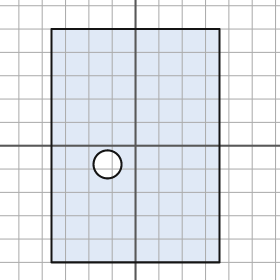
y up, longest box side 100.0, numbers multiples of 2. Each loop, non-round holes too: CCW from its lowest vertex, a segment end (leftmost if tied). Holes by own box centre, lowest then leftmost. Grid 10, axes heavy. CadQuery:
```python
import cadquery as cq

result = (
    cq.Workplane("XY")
    .moveTo(-36.0, -50.0)
    .lineTo(36.0, -50.0)
    .lineTo(36.0, 50.0)
    .lineTo(-36.0, 50.0)
    .close()
    .moveTo(-12.0, -8.0)
    .circle(6.0)
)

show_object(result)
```